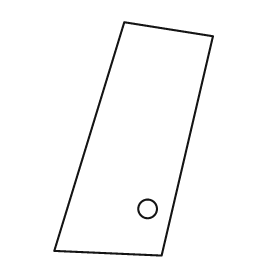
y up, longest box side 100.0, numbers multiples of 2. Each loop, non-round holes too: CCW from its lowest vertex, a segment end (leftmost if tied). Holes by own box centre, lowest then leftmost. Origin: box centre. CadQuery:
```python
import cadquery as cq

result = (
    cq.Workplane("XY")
    .moveTo(12.0, -50.0)
    .lineTo(34.0, 44.0)
    .lineTo(-4.0, 50.0)
    .lineTo(-34.0, -48.0)
    .close()
    .moveTo(6.0, -30.0)
    .circle(4.0)
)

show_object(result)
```